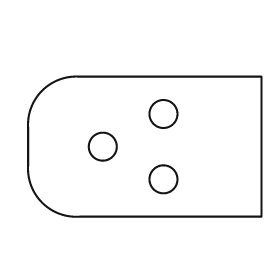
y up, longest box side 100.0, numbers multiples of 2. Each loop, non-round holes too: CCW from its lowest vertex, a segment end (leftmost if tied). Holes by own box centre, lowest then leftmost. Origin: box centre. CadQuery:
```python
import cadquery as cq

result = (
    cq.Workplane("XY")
    .moveTo(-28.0, -30.0)
    .lineTo(50.0, -30.0)
    .lineTo(50.0, 30.0)
    .lineTo(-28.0, 30.0)
    .threePointArc((-44.0, 24.0), (-50.0, 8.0))
    .lineTo(-50.0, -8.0)
    .threePointArc((-44.0, -24.0), (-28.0, -30.0))
    .close()
    .moveTo(8.0, -14.0)
    .circle(6.0)
    .moveTo(-18.0, 0.0)
    .circle(6.0)
    .moveTo(8.0, 14.0)
    .circle(6.0)
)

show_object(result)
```